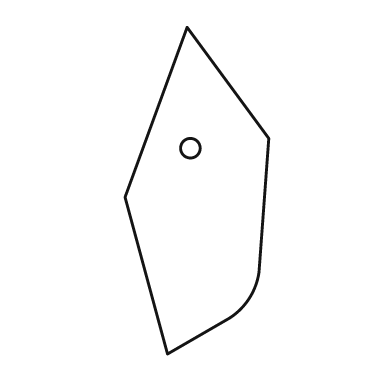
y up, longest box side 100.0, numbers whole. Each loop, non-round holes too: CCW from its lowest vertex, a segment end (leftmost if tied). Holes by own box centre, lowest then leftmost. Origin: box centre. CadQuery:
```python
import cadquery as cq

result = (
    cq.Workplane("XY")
    .moveTo(-9.0, -50.0)
    .lineTo(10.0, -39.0)
    .threePointArc((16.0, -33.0), (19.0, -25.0))
    .lineTo(22.0, 16.0)
    .lineTo(-3.0, 50.0)
    .lineTo(-22.0, -2.0)
    .close()
    .moveTo(-2.0, 13.0)
    .circle(3.0)
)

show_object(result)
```